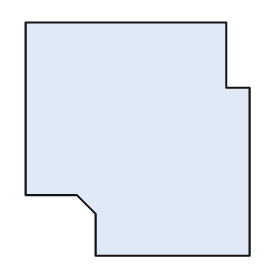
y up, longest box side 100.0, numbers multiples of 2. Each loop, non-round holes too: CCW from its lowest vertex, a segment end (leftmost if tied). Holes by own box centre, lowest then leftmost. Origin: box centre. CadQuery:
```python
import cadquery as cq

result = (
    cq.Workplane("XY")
    .moveTo(-18.0, -50.0)
    .lineTo(48.0, -50.0)
    .lineTo(48.0, 22.0)
    .lineTo(38.0, 22.0)
    .lineTo(38.0, 50.0)
    .lineTo(-48.0, 50.0)
    .lineTo(-48.0, -24.0)
    .lineTo(-26.0, -24.0)
    .lineTo(-18.0, -32.0)
    .close()
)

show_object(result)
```